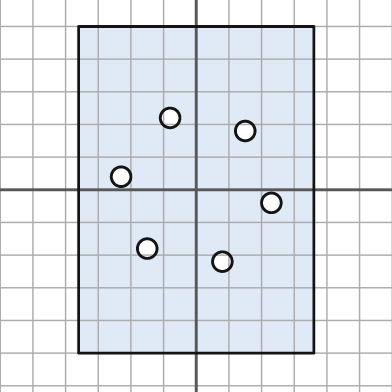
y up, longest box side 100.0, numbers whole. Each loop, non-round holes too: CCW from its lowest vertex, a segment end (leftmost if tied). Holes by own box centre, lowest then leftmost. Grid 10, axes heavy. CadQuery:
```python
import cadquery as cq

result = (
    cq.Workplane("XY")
    .moveTo(-36.0, -50.0)
    .lineTo(36.0, -50.0)
    .lineTo(36.0, 50.0)
    .lineTo(-36.0, 50.0)
    .close()
    .moveTo(8.0, -22.0)
    .circle(3.0)
    .moveTo(-15.0, -18.0)
    .circle(3.0)
    .moveTo(23.0, -4.0)
    .circle(3.0)
    .moveTo(-23.0, 4.0)
    .circle(3.0)
    .moveTo(15.0, 18.0)
    .circle(3.0)
    .moveTo(-8.0, 22.0)
    .circle(3.0)
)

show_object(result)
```